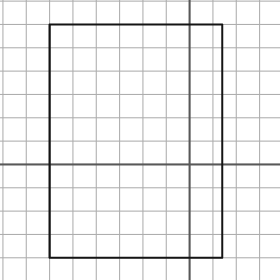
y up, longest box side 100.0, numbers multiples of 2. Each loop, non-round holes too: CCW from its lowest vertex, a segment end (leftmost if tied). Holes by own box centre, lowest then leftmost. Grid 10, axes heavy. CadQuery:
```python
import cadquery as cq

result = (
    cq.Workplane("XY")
    .moveTo(-60.0, -40.0)
    .lineTo(14.0, -40.0)
    .lineTo(14.0, 60.0)
    .lineTo(-60.0, 60.0)
    .close()
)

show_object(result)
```